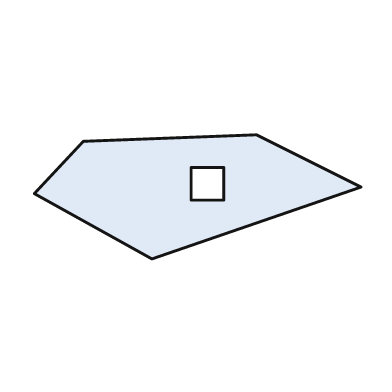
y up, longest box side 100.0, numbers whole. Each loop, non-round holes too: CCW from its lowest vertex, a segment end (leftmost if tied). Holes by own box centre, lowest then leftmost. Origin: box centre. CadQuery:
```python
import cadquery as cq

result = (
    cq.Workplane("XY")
    .moveTo(-14.0, -19.0)
    .lineTo(50.0, 3.0)
    .lineTo(18.0, 19.0)
    .lineTo(-35.0, 17.0)
    .lineTo(-50.0, 1.0)
    .close()
    .moveTo(-2.0, -1.0)
    .lineTo(8.0, -1.0)
    .lineTo(8.0, 9.0)
    .lineTo(-2.0, 9.0)
    .close()
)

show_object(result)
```